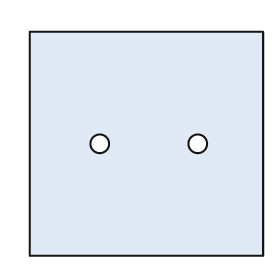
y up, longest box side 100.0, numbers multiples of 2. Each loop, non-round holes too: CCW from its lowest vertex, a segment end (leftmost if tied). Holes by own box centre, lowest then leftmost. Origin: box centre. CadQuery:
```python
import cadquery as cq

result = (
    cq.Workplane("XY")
    .moveTo(-50.0, -48.0)
    .lineTo(50.0, -48.0)
    .lineTo(50.0, 48.0)
    .lineTo(-50.0, 48.0)
    .close()
    .moveTo(-20.0, 0.0)
    .circle(4.0)
    .moveTo(22.0, 0.0)
    .circle(4.0)
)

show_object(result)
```